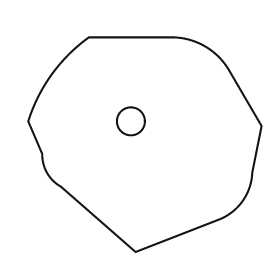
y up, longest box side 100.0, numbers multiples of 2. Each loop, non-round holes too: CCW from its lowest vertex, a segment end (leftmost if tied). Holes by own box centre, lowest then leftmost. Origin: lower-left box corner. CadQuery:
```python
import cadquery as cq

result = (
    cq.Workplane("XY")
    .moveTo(46.0, 0.0)
    .lineTo(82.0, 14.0)
    .threePointArc((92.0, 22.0), (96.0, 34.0))
    .lineTo(100.0, 54.0)
    .lineTo(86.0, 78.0)
    .threePointArc((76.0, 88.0), (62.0, 92.0))
    .lineTo(26.0, 92.0)
    .threePointArc((10.0, 76.0), (0.0, 56.0))
    .lineTo(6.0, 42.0)
    .threePointArc((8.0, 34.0), (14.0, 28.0))
    .close()
    .moveTo(44.0, 56.0)
    .circle(6.0)
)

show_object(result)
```